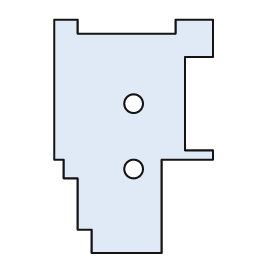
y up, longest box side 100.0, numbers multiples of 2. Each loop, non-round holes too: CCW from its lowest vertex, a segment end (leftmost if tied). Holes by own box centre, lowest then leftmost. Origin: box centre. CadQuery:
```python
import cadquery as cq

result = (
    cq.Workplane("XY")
    .moveTo(-18.0, -50.0)
    .lineTo(12.0, -50.0)
    .lineTo(12.0, -10.0)
    .lineTo(34.0, -10.0)
    .lineTo(34.0, -6.0)
    .lineTo(22.0, -6.0)
    .lineTo(22.0, 34.0)
    .lineTo(34.0, 34.0)
    .lineTo(34.0, 50.0)
    .lineTo(18.0, 50.0)
    .lineTo(18.0, 44.0)
    .lineTo(-24.0, 44.0)
    .lineTo(-24.0, 50.0)
    .lineTo(-34.0, 50.0)
    .lineTo(-34.0, -10.0)
    .lineTo(-30.0, -10.0)
    .lineTo(-30.0, -18.0)
    .lineTo(-24.0, -18.0)
    .lineTo(-24.0, -40.0)
    .lineTo(-18.0, -40.0)
    .close()
    .moveTo(0.0, -14.0)
    .circle(4.0)
    .moveTo(0.0, 14.0)
    .circle(4.0)
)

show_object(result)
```